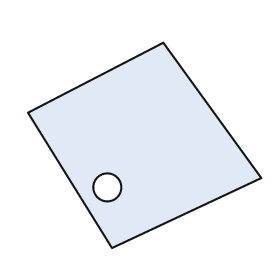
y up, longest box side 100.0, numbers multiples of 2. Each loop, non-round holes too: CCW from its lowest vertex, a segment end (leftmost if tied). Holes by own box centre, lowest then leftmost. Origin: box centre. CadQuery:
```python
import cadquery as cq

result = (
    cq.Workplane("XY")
    .moveTo(-14.0, -44.0)
    .lineTo(50.0, -14.0)
    .lineTo(8.0, 44.0)
    .lineTo(-50.0, 14.0)
    .close()
    .moveTo(-16.0, -18.0)
    .circle(6.0)
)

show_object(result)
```